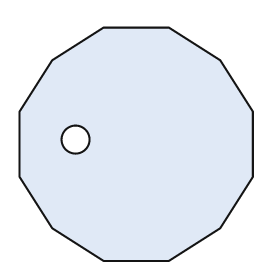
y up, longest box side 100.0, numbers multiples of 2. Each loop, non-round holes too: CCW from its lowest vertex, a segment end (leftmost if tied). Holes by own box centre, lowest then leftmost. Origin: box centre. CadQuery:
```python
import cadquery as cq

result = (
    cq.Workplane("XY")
    .moveTo(-14.0, -50.0)
    .lineTo(14.0, -50.0)
    .lineTo(36.0, -36.0)
    .lineTo(50.0, -14.0)
    .lineTo(50.0, 14.0)
    .lineTo(36.0, 36.0)
    .lineTo(14.0, 50.0)
    .lineTo(-14.0, 50.0)
    .lineTo(-36.0, 36.0)
    .lineTo(-50.0, 14.0)
    .lineTo(-50.0, -14.0)
    .lineTo(-36.0, -36.0)
    .close()
    .moveTo(-26.0, 2.0)
    .circle(6.0)
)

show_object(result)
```